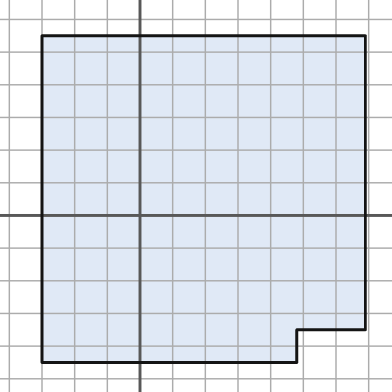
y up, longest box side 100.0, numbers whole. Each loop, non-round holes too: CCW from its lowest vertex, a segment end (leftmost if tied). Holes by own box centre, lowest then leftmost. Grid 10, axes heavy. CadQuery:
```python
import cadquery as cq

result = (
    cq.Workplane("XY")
    .moveTo(-30.0, -45.0)
    .lineTo(48.0, -45.0)
    .lineTo(48.0, -35.0)
    .lineTo(69.0, -35.0)
    .lineTo(69.0, 55.0)
    .lineTo(-30.0, 55.0)
    .close()
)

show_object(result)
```